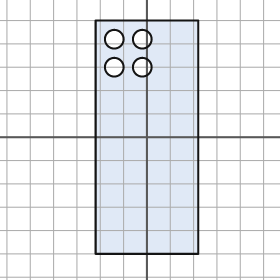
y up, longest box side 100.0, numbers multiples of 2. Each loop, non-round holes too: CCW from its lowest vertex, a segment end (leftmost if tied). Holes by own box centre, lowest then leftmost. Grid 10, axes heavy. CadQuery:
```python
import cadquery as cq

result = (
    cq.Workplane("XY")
    .moveTo(-22.0, -50.0)
    .lineTo(22.0, -50.0)
    .lineTo(22.0, 50.0)
    .lineTo(-22.0, 50.0)
    .close()
    .moveTo(-14.0, 30.0)
    .circle(4.0)
    .moveTo(-2.0, 30.0)
    .circle(4.0)
    .moveTo(-14.0, 42.0)
    .circle(4.0)
    .moveTo(-2.0, 42.0)
    .circle(4.0)
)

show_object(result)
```